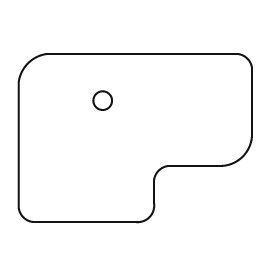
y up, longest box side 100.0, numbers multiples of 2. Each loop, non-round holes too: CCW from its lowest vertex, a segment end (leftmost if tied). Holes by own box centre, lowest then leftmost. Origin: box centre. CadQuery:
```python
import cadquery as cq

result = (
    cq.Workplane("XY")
    .moveTo(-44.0, -36.0)
    .lineTo(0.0, -36.0)
    .threePointArc((6.0, -34.0), (8.0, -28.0))
    .lineTo(8.0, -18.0)
    .threePointArc((10.0, -14.0), (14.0, -12.0))
    .lineTo(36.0, -12.0)
    .threePointArc((46.0, -8.0), (50.0, 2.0))
    .lineTo(50.0, 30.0)
    .threePointArc((48.0, 34.0), (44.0, 36.0))
    .lineTo(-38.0, 36.0)
    .threePointArc((-46.0, 32.0), (-50.0, 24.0))
    .lineTo(-50.0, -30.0)
    .threePointArc((-48.0, -34.0), (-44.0, -36.0))
    .close()
    .moveTo(-14.0, 16.0)
    .circle(4.0)
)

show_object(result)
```